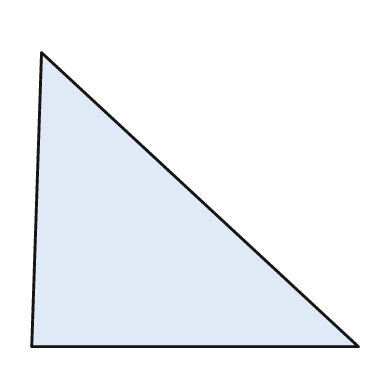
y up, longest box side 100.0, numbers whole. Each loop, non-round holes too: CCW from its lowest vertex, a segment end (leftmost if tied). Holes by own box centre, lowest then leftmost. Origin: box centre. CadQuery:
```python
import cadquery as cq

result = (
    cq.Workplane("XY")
    .moveTo(-50.0, -45.0)
    .lineTo(50.0, -45.0)
    .lineTo(-47.0, 45.0)
    .close()
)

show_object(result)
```